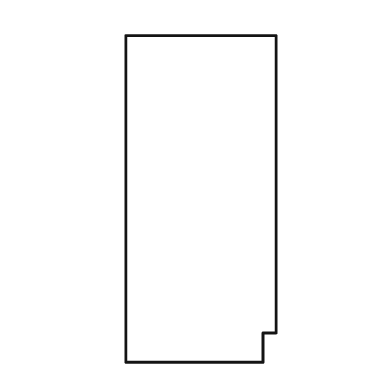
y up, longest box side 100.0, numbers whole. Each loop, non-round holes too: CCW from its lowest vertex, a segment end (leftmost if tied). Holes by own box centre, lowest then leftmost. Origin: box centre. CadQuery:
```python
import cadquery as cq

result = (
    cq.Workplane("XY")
    .moveTo(-23.0, -50.0)
    .lineTo(19.0, -50.0)
    .lineTo(19.0, -41.0)
    .lineTo(23.0, -41.0)
    .lineTo(23.0, 50.0)
    .lineTo(-23.0, 50.0)
    .close()
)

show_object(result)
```